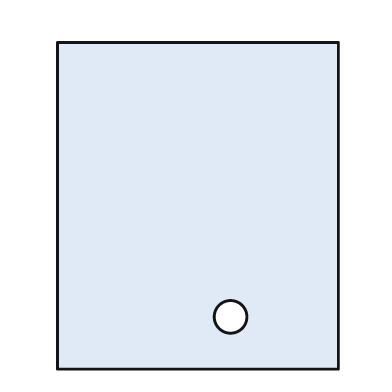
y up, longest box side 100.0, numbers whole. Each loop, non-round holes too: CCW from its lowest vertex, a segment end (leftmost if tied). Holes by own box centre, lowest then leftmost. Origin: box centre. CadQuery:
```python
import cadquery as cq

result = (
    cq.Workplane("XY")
    .moveTo(-43.0, -50.0)
    .lineTo(43.0, -50.0)
    .lineTo(43.0, 50.0)
    .lineTo(-43.0, 50.0)
    .close()
    .moveTo(10.0, -34.0)
    .circle(5.0)
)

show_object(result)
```